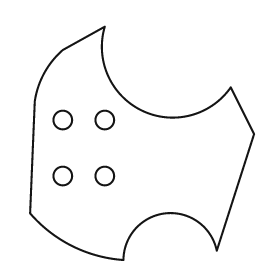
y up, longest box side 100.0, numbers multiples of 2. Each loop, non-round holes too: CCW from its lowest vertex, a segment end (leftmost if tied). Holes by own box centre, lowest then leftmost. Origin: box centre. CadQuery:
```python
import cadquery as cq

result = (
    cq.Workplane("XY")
    .moveTo(-8.0, -50.0)
    .threePointArc((10.0, -30.0), (32.0, -46.0))
    .lineTo(48.0, 4.0)
    .lineTo(38.0, 24.0)
    .threePointArc((0.0, 14.0), (-16.0, 50.0))
    .lineTo(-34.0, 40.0)
    .threePointArc((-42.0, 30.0), (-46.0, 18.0))
    .lineTo(-48.0, -30.0)
    .threePointArc((-30.0, -44.0), (-8.0, -50.0))
    .close()
    .moveTo(-34.0, -14.0)
    .circle(4.0)
    .moveTo(-16.0, -14.0)
    .circle(4.0)
    .moveTo(-34.0, 10.0)
    .circle(4.0)
    .moveTo(-16.0, 10.0)
    .circle(4.0)
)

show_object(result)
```